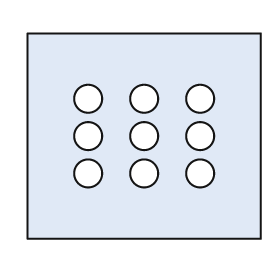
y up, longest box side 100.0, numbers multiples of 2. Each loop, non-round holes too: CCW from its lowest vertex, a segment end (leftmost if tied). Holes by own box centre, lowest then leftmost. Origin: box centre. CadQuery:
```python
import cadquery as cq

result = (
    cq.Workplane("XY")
    .moveTo(-50.0, -44.0)
    .lineTo(50.0, -44.0)
    .lineTo(50.0, 44.0)
    .lineTo(-50.0, 44.0)
    .close()
    .moveTo(-24.0, -16.0)
    .circle(6.0)
    .moveTo(0.0, -16.0)
    .circle(6.0)
    .moveTo(24.0, -16.0)
    .circle(6.0)
    .moveTo(-24.0, 0.0)
    .circle(6.0)
    .moveTo(0.0, 0.0)
    .circle(6.0)
    .moveTo(24.0, 0.0)
    .circle(6.0)
    .moveTo(-24.0, 16.0)
    .circle(6.0)
    .moveTo(0.0, 16.0)
    .circle(6.0)
    .moveTo(24.0, 16.0)
    .circle(6.0)
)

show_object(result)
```